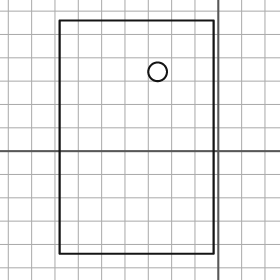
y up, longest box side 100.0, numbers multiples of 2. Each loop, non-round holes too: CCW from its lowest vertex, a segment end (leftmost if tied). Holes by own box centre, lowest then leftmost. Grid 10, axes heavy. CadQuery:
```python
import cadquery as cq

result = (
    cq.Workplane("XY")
    .moveTo(-68.0, -44.0)
    .lineTo(-2.0, -44.0)
    .lineTo(-2.0, 56.0)
    .lineTo(-68.0, 56.0)
    .close()
    .moveTo(-26.0, 34.0)
    .circle(4.0)
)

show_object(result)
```